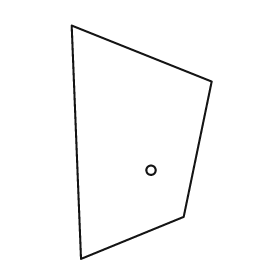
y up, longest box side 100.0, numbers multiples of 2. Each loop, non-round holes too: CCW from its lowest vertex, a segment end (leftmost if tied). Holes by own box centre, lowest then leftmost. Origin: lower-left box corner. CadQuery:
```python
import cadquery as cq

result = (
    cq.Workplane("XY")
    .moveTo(4.0, 0.0)
    .lineTo(48.0, 18.0)
    .lineTo(60.0, 76.0)
    .lineTo(0.0, 100.0)
    .close()
    .moveTo(34.0, 38.0)
    .circle(2.0)
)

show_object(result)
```